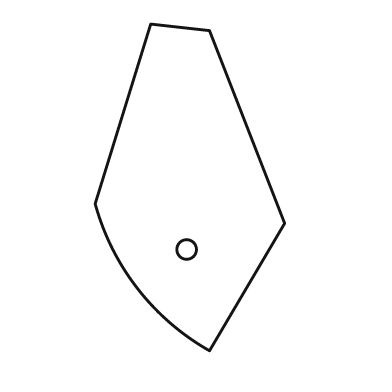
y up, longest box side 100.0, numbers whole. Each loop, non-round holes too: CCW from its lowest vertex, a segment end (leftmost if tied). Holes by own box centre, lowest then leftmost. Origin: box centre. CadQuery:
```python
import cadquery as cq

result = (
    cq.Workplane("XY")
    .moveTo(6.0, -50.0)
    .lineTo(29.0, -11.0)
    .lineTo(6.0, 48.0)
    .lineTo(-12.0, 50.0)
    .lineTo(-29.0, -5.0)
    .threePointArc((-16.0, -31.0), (6.0, -50.0))
    .close()
    .moveTo(-1.0, -19.0)
    .circle(3.0)
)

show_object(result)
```